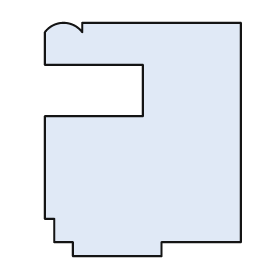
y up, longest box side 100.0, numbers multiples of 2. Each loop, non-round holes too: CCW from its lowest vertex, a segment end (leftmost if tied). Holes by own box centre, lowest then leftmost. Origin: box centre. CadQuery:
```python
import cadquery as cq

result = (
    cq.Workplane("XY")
    .moveTo(-30.0, -50.0)
    .lineTo(8.0, -50.0)
    .lineTo(8.0, -44.0)
    .lineTo(42.0, -44.0)
    .lineTo(42.0, 50.0)
    .lineTo(-26.0, 50.0)
    .lineTo(-26.0, 46.0)
    .threePointArc((-34.0, 50.0), (-42.0, 46.0))
    .lineTo(-42.0, 32.0)
    .lineTo(0.0, 32.0)
    .lineTo(0.0, 10.0)
    .lineTo(-42.0, 10.0)
    .lineTo(-42.0, -34.0)
    .lineTo(-38.0, -34.0)
    .lineTo(-38.0, -44.0)
    .lineTo(-30.0, -44.0)
    .close()
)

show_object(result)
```